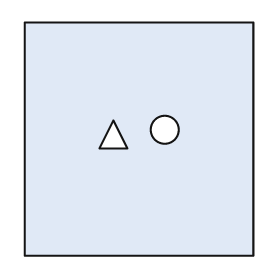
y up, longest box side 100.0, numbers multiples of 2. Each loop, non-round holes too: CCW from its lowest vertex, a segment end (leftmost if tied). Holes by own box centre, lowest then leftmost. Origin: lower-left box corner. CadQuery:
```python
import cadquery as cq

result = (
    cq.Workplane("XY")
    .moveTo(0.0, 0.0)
    .lineTo(98.0, 0.0)
    .lineTo(98.0, 100.0)
    .lineTo(0.0, 100.0)
    .close()
    .moveTo(32.0, 46.0)
    .lineTo(44.0, 46.0)
    .lineTo(38.0, 58.0)
    .close()
    .moveTo(60.0, 54.0)
    .circle(6.0)
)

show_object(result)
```